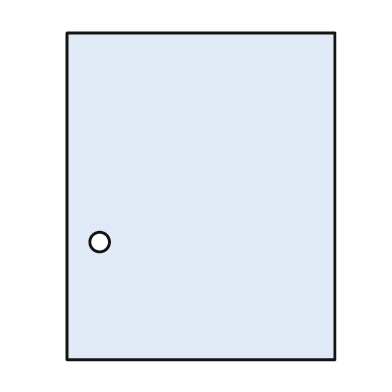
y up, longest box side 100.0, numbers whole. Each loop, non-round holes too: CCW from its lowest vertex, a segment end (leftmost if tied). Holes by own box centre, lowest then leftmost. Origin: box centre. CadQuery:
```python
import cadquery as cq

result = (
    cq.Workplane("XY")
    .moveTo(-41.0, -50.0)
    .lineTo(41.0, -50.0)
    .lineTo(41.0, 50.0)
    .lineTo(-41.0, 50.0)
    .close()
    .moveTo(-31.0, -14.0)
    .circle(3.0)
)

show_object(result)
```